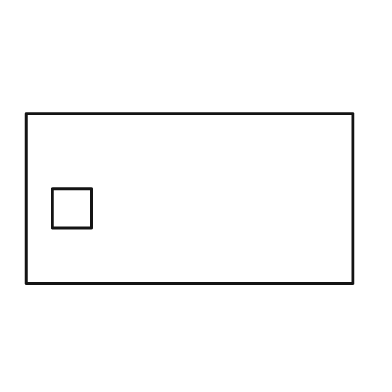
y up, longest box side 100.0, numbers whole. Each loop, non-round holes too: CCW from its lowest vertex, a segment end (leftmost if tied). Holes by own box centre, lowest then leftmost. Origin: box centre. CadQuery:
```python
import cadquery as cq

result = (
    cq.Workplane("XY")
    .moveTo(-50.0, -26.0)
    .lineTo(50.0, -26.0)
    .lineTo(50.0, 26.0)
    .lineTo(-50.0, 26.0)
    .close()
    .moveTo(-42.0, -9.0)
    .lineTo(-30.0, -9.0)
    .lineTo(-30.0, 3.0)
    .lineTo(-42.0, 3.0)
    .close()
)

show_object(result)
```